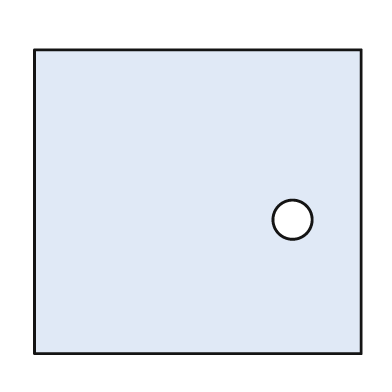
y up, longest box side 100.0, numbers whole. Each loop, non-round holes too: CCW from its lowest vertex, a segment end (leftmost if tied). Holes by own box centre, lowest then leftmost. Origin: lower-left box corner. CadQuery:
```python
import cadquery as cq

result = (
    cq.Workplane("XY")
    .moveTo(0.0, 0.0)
    .lineTo(100.0, 0.0)
    .lineTo(100.0, 93.0)
    .lineTo(0.0, 93.0)
    .close()
    .moveTo(79.0, 41.0)
    .circle(6.0)
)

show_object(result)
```